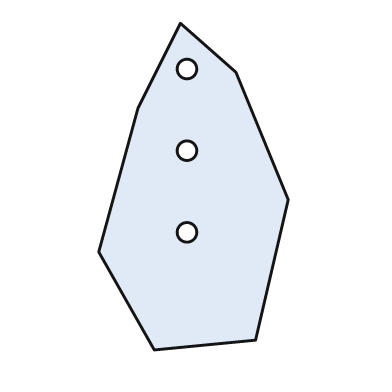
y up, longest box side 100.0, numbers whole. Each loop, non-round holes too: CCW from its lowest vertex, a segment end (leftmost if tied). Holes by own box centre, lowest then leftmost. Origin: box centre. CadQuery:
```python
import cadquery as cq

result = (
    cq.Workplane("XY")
    .moveTo(-12.0, -50.0)
    .lineTo(19.0, -47.0)
    .lineTo(29.0, -4.0)
    .lineTo(13.0, 35.0)
    .lineTo(-4.0, 50.0)
    .lineTo(-17.0, 24.0)
    .lineTo(-29.0, -20.0)
    .close()
    .moveTo(-2.0, -14.0)
    .circle(3.0)
    .moveTo(-2.0, 11.0)
    .circle(3.0)
    .moveTo(-2.0, 36.0)
    .circle(3.0)
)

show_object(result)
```